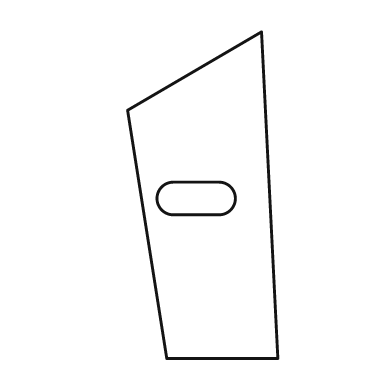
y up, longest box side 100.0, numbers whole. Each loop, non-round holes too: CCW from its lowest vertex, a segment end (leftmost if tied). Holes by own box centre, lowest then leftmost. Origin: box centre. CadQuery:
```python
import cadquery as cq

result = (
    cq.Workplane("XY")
    .moveTo(-11.0, -50.0)
    .lineTo(23.0, -50.0)
    .lineTo(18.0, 50.0)
    .lineTo(-23.0, 26.0)
    .close()
    .moveTo(-9.0, -6.0)
    .lineTo(5.0, -6.0)
    .threePointArc((10.0, -1.0), (5.0, 4.0))
    .lineTo(-9.0, 4.0)
    .threePointArc((-14.0, -1.0), (-9.0, -6.0))
    .close()
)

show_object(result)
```